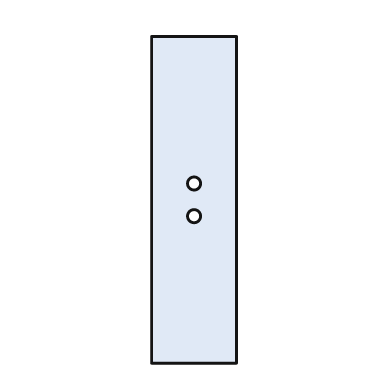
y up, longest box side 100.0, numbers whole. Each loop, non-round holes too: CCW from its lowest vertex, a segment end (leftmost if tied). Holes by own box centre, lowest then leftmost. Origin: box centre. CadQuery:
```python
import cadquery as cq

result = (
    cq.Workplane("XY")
    .moveTo(-13.0, -50.0)
    .lineTo(13.0, -50.0)
    .lineTo(13.0, 50.0)
    .lineTo(-13.0, 50.0)
    .close()
    .moveTo(0.0, -5.0)
    .circle(2.0)
    .moveTo(0.0, 5.0)
    .circle(2.0)
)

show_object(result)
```